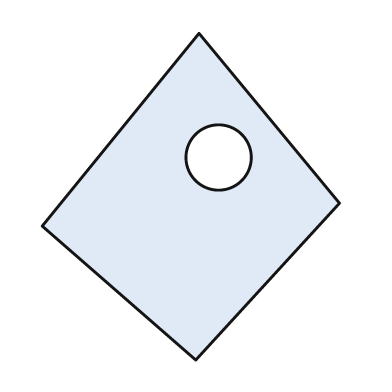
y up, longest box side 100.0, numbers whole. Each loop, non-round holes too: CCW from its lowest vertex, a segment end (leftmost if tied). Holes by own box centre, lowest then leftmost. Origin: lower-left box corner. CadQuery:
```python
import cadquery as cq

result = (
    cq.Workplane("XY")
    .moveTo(47.0, 0.0)
    .lineTo(91.0, 48.0)
    .lineTo(48.0, 100.0)
    .lineTo(0.0, 41.0)
    .close()
    .moveTo(54.0, 62.0)
    .circle(10.0)
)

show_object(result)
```